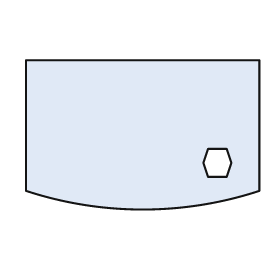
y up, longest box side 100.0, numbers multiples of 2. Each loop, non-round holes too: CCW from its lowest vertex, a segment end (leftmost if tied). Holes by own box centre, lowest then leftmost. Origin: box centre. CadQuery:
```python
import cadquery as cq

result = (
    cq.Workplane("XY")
    .moveTo(-50.0, -24.0)
    .threePointArc((0.0, -32.0), (50.0, -24.0))
    .lineTo(50.0, 32.0)
    .lineTo(-50.0, 32.0)
    .close()
    .moveTo(28.0, -18.0)
    .lineTo(36.0, -18.0)
    .lineTo(38.0, -12.0)
    .lineTo(36.0, -6.0)
    .lineTo(28.0, -6.0)
    .lineTo(26.0, -12.0)
    .close()
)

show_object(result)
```